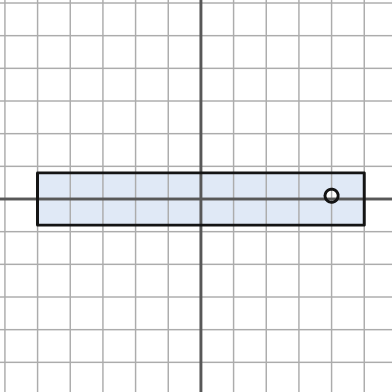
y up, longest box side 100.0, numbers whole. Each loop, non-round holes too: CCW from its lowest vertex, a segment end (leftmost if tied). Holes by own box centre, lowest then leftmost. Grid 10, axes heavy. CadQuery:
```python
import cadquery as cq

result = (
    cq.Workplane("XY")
    .moveTo(-50.0, -8.0)
    .lineTo(50.0, -8.0)
    .lineTo(50.0, 8.0)
    .lineTo(-50.0, 8.0)
    .close()
    .moveTo(40.0, 1.0)
    .circle(2.0)
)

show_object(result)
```